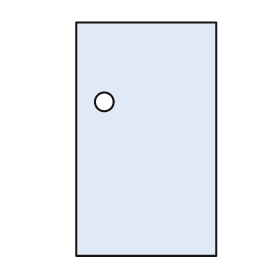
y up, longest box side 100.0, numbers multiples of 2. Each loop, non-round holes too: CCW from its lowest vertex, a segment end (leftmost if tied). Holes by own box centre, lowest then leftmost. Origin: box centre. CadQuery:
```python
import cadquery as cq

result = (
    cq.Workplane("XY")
    .moveTo(-30.0, -50.0)
    .lineTo(30.0, -50.0)
    .lineTo(30.0, 50.0)
    .lineTo(-30.0, 50.0)
    .close()
    .moveTo(-18.0, 16.0)
    .circle(4.0)
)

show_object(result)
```